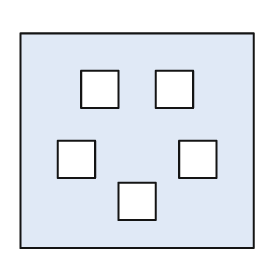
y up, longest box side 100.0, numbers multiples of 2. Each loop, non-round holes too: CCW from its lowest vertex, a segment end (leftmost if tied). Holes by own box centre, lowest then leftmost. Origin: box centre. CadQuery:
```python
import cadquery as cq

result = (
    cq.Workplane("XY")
    .moveTo(-50.0, -46.0)
    .lineTo(50.0, -46.0)
    .lineTo(50.0, 46.0)
    .lineTo(-50.0, 46.0)
    .close()
    .moveTo(-8.0, -34.0)
    .lineTo(8.0, -34.0)
    .lineTo(8.0, -18.0)
    .lineTo(-8.0, -18.0)
    .close()
    .moveTo(-34.0, -16.0)
    .lineTo(-18.0, -16.0)
    .lineTo(-18.0, 0.0)
    .lineTo(-34.0, 0.0)
    .close()
    .moveTo(18.0, -16.0)
    .lineTo(34.0, -16.0)
    .lineTo(34.0, 0.0)
    .lineTo(18.0, 0.0)
    .close()
    .moveTo(-24.0, 14.0)
    .lineTo(-8.0, 14.0)
    .lineTo(-8.0, 30.0)
    .lineTo(-24.0, 30.0)
    .close()
    .moveTo(8.0, 14.0)
    .lineTo(24.0, 14.0)
    .lineTo(24.0, 30.0)
    .lineTo(8.0, 30.0)
    .close()
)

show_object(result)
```